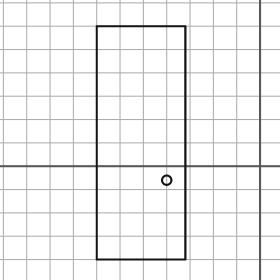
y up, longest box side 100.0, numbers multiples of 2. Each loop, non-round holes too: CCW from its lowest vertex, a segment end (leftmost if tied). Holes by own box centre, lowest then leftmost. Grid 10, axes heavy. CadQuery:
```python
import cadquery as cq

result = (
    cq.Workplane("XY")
    .moveTo(-70.0, -40.0)
    .lineTo(-32.0, -40.0)
    .lineTo(-32.0, 60.0)
    .lineTo(-70.0, 60.0)
    .close()
    .moveTo(-40.0, -6.0)
    .circle(2.0)
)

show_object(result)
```